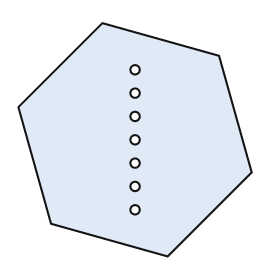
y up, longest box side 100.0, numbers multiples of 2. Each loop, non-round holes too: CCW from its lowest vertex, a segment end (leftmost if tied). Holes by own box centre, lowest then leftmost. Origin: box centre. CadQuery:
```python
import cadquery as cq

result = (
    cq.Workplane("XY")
    .moveTo(14.0, -50.0)
    .lineTo(50.0, -14.0)
    .lineTo(36.0, 36.0)
    .lineTo(-14.0, 50.0)
    .lineTo(-50.0, 14.0)
    .lineTo(-36.0, -36.0)
    .close()
    .moveTo(0.0, -30.0)
    .circle(2.0)
    .moveTo(0.0, -20.0)
    .circle(2.0)
    .moveTo(0.0, -10.0)
    .circle(2.0)
    .moveTo(0.0, 0.0)
    .circle(2.0)
    .moveTo(0.0, 10.0)
    .circle(2.0)
    .moveTo(0.0, 20.0)
    .circle(2.0)
    .moveTo(0.0, 30.0)
    .circle(2.0)
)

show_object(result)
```